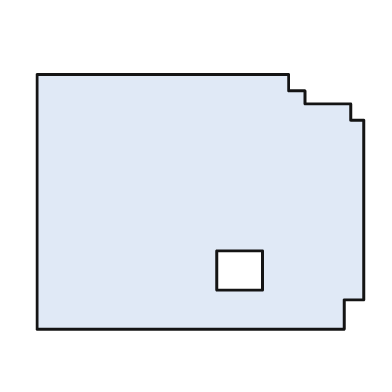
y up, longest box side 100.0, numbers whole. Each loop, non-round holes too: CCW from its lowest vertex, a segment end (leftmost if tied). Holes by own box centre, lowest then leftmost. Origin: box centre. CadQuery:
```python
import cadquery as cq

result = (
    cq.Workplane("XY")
    .moveTo(-50.0, -39.0)
    .lineTo(44.0, -39.0)
    .lineTo(44.0, -30.0)
    .lineTo(50.0, -30.0)
    .lineTo(50.0, 25.0)
    .lineTo(46.0, 25.0)
    .lineTo(46.0, 30.0)
    .lineTo(32.0, 30.0)
    .lineTo(32.0, 34.0)
    .lineTo(27.0, 34.0)
    .lineTo(27.0, 39.0)
    .lineTo(-50.0, 39.0)
    .close()
    .moveTo(5.0, -27.0)
    .lineTo(19.0, -27.0)
    .lineTo(19.0, -15.0)
    .lineTo(5.0, -15.0)
    .close()
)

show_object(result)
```